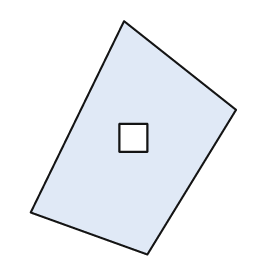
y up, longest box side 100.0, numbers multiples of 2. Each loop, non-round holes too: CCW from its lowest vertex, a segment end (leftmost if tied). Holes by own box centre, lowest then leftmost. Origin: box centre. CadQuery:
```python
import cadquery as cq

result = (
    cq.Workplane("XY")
    .moveTo(6.0, -50.0)
    .lineTo(44.0, 12.0)
    .lineTo(-4.0, 50.0)
    .lineTo(-44.0, -32.0)
    .close()
    .moveTo(-6.0, -6.0)
    .lineTo(6.0, -6.0)
    .lineTo(6.0, 6.0)
    .lineTo(-6.0, 6.0)
    .close()
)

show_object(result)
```